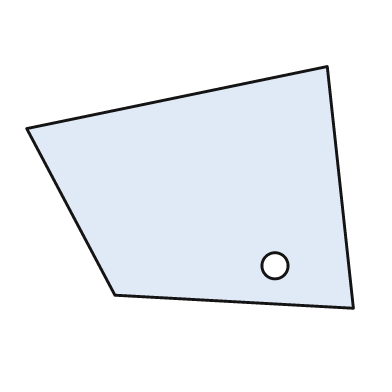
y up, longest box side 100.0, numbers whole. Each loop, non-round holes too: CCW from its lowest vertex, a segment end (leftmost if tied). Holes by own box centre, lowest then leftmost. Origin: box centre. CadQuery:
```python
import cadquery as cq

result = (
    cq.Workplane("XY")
    .moveTo(50.0, -37.0)
    .lineTo(42.0, 37.0)
    .lineTo(-50.0, 18.0)
    .lineTo(-23.0, -33.0)
    .close()
    .moveTo(26.0, -24.0)
    .circle(4.0)
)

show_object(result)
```